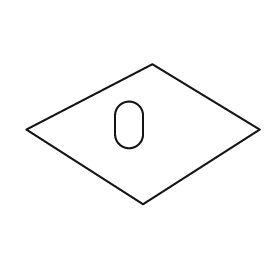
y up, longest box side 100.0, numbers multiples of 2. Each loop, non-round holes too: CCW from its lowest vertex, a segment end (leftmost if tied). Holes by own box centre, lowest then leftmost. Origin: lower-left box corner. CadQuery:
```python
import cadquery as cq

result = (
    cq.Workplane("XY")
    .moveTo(50.0, 0.0)
    .lineTo(100.0, 32.0)
    .lineTo(54.0, 60.0)
    .lineTo(0.0, 32.0)
    .close()
    .moveTo(38.0, 30.0)
    .threePointArc((44.0, 24.0), (50.0, 30.0))
    .lineTo(50.0, 38.0)
    .threePointArc((44.0, 44.0), (38.0, 38.0))
    .close()
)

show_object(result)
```